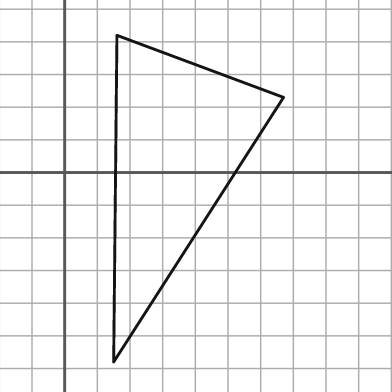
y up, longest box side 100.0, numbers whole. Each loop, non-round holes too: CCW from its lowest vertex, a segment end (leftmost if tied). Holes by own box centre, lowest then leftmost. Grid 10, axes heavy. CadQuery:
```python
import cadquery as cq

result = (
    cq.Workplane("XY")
    .moveTo(15.0, -58.0)
    .lineTo(67.0, 23.0)
    .lineTo(16.0, 42.0)
    .close()
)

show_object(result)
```